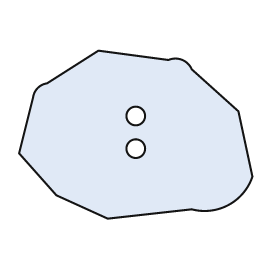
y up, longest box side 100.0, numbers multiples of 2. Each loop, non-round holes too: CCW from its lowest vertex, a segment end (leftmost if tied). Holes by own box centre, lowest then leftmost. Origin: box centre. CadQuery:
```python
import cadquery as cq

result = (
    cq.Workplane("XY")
    .moveTo(-12.0, -36.0)
    .lineTo(24.0, -32.0)
    .threePointArc((40.0, -30.0), (50.0, -18.0))
    .lineTo(44.0, 10.0)
    .lineTo(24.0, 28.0)
    .threePointArc((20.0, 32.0), (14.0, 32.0))
    .lineTo(-16.0, 36.0)
    .lineTo(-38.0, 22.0)
    .threePointArc((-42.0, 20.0), (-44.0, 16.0))
    .lineTo(-50.0, -8.0)
    .lineTo(-34.0, -26.0)
    .close()
    .moveTo(0.0, -6.0)
    .circle(4.0)
    .moveTo(0.0, 8.0)
    .circle(4.0)
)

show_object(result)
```